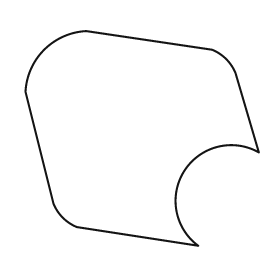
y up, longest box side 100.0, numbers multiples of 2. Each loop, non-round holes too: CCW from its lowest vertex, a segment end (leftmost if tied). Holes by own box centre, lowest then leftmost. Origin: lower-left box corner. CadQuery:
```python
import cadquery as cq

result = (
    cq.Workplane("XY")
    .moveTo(74.0, 0.0)
    .threePointArc((68.0, 32.0), (100.0, 40.0))
    .lineTo(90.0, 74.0)
    .threePointArc((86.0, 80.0), (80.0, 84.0))
    .lineTo(26.0, 92.0)
    .threePointArc((8.0, 84.0), (0.0, 66.0))
    .lineTo(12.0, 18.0)
    .threePointArc((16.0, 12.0), (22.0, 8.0))
    .close()
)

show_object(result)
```